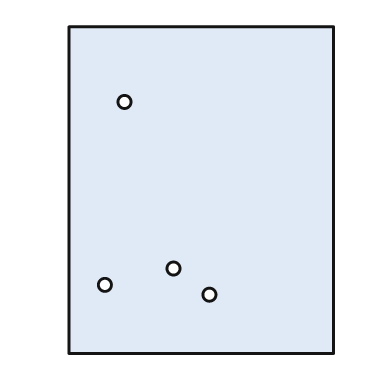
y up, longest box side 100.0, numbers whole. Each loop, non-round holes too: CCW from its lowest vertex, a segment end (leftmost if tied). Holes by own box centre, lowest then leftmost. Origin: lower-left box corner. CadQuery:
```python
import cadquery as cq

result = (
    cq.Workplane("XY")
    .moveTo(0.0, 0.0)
    .lineTo(81.0, 0.0)
    .lineTo(81.0, 100.0)
    .lineTo(0.0, 100.0)
    .close()
    .moveTo(43.0, 18.0)
    .circle(2.0)
    .moveTo(11.0, 21.0)
    .circle(2.0)
    .moveTo(32.0, 26.0)
    .circle(2.0)
    .moveTo(17.0, 77.0)
    .circle(2.0)
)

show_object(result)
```